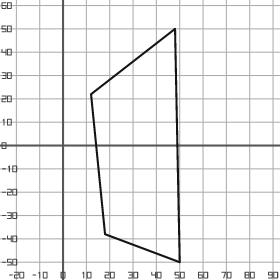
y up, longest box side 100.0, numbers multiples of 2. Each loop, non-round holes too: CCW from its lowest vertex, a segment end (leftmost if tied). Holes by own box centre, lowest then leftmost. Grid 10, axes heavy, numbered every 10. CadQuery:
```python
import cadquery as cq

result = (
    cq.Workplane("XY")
    .moveTo(50.0, -50.0)
    .lineTo(48.0, 50.0)
    .lineTo(12.0, 22.0)
    .lineTo(18.0, -38.0)
    .close()
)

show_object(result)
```